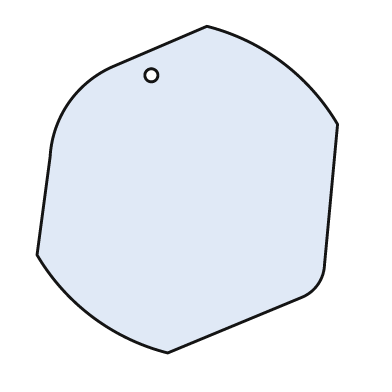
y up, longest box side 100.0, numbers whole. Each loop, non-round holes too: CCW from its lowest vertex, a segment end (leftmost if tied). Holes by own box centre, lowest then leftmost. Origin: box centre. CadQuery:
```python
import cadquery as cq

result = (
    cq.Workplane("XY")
    .moveTo(-6.0, -50.0)
    .lineTo(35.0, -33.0)
    .threePointArc((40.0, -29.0), (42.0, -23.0))
    .lineTo(46.0, 20.0)
    .threePointArc((29.0, 39.0), (6.0, 50.0))
    .lineTo(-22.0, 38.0)
    .threePointArc((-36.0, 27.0), (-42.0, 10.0))
    .lineTo(-46.0, -20.0)
    .threePointArc((-29.0, -39.0), (-6.0, -50.0))
    .close()
    .moveTo(-11.0, 35.0)
    .circle(2.0)
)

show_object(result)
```